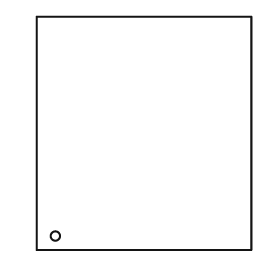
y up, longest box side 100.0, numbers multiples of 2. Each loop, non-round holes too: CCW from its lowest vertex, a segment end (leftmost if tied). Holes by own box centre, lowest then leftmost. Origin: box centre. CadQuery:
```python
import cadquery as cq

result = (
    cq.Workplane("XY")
    .moveTo(-46.0, -50.0)
    .lineTo(46.0, -50.0)
    .lineTo(46.0, 50.0)
    .lineTo(-46.0, 50.0)
    .close()
    .moveTo(-38.0, -44.0)
    .circle(2.0)
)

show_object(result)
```